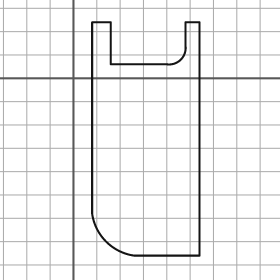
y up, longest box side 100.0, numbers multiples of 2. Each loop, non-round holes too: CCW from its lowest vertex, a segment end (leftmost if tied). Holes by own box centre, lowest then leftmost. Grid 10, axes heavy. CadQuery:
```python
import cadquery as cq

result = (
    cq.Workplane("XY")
    .moveTo(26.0, -76.0)
    .lineTo(54.0, -76.0)
    .lineTo(54.0, 24.0)
    .lineTo(48.0, 24.0)
    .lineTo(48.0, 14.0)
    .threePointArc((46.0, 8.0), (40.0, 6.0))
    .lineTo(16.0, 6.0)
    .lineTo(16.0, 24.0)
    .lineTo(8.0, 24.0)
    .lineTo(8.0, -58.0)
    .threePointArc((14.0, -70.0), (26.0, -76.0))
    .close()
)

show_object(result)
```